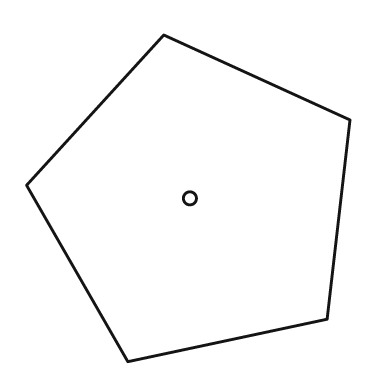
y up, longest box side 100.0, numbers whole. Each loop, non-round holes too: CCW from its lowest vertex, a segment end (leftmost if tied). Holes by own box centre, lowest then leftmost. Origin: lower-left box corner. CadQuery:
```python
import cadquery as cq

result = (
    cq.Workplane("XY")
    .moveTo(31.0, 0.0)
    .lineTo(92.0, 13.0)
    .lineTo(99.0, 74.0)
    .lineTo(42.0, 100.0)
    .lineTo(0.0, 54.0)
    .close()
    .moveTo(50.0, 50.0)
    .circle(2.0)
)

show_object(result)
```